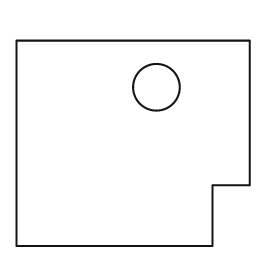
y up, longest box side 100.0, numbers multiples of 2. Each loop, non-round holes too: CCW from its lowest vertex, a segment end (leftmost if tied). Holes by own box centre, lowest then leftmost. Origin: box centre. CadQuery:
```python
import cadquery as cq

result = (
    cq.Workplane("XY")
    .moveTo(-50.0, -44.0)
    .lineTo(34.0, -44.0)
    .lineTo(34.0, -18.0)
    .lineTo(50.0, -18.0)
    .lineTo(50.0, 44.0)
    .lineTo(-50.0, 44.0)
    .close()
    .moveTo(10.0, 24.0)
    .circle(10.0)
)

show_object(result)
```